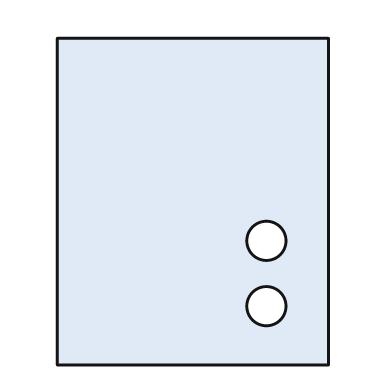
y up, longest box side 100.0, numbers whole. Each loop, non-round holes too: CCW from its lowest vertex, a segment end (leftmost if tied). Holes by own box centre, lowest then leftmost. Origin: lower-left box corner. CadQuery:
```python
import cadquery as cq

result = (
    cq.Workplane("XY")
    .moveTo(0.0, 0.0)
    .lineTo(83.0, 0.0)
    .lineTo(83.0, 100.0)
    .lineTo(0.0, 100.0)
    .close()
    .moveTo(64.0, 18.0)
    .circle(6.0)
    .moveTo(64.0, 38.0)
    .circle(6.0)
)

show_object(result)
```